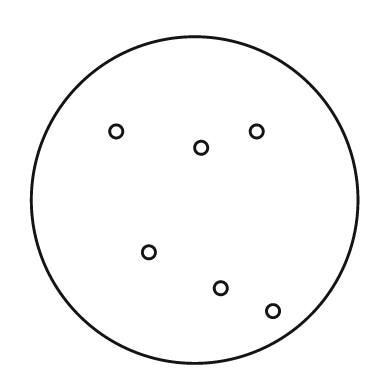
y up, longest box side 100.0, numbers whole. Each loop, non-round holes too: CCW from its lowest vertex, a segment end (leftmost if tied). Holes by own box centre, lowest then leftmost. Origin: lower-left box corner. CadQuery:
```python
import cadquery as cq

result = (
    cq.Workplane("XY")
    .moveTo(50.0, 50.0)
    .circle(50.0)
    .moveTo(74.0, 16.0)
    .circle(2.0)
    .moveTo(58.0, 23.0)
    .circle(2.0)
    .moveTo(36.0, 34.0)
    .circle(2.0)
    .moveTo(52.0, 66.0)
    .circle(2.0)
    .moveTo(26.0, 71.0)
    .circle(2.0)
    .moveTo(69.0, 71.0)
    .circle(2.0)
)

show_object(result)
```